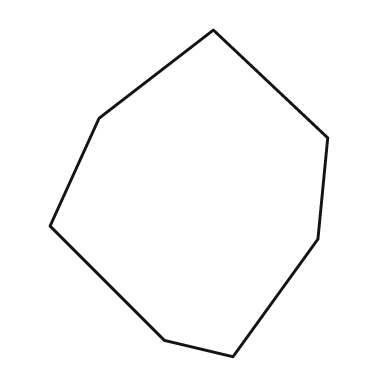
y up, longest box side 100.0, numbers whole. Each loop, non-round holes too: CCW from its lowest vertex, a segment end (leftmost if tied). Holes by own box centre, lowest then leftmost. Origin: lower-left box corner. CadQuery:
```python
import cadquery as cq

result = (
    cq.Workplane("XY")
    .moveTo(56.0, 0.0)
    .lineTo(82.0, 36.0)
    .lineTo(85.0, 67.0)
    .lineTo(50.0, 100.0)
    .lineTo(15.0, 73.0)
    .lineTo(0.0, 40.0)
    .lineTo(35.0, 5.0)
    .close()
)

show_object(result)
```